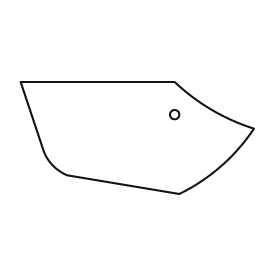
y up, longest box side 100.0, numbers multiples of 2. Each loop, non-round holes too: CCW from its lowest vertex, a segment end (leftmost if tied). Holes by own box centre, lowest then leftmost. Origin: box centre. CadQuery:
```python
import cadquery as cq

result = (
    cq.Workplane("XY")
    .moveTo(18.0, -24.0)
    .threePointArc((36.0, -12.0), (50.0, 4.0))
    .threePointArc((32.0, 12.0), (16.0, 24.0))
    .lineTo(-50.0, 24.0)
    .lineTo(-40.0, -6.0)
    .threePointArc((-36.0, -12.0), (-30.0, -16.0))
    .close()
    .moveTo(16.0, 10.0)
    .circle(2.0)
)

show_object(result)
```